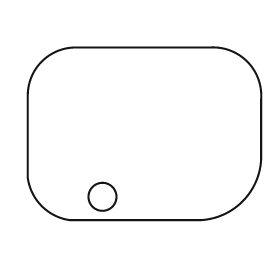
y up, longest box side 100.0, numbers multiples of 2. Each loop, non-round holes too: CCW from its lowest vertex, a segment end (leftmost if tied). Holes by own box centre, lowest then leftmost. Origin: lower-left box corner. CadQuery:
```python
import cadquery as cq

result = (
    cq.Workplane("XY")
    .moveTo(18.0, 0.0)
    .lineTo(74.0, 0.0)
    .threePointArc((92.0, 8.0), (100.0, 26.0))
    .lineTo(100.0, 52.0)
    .threePointArc((94.0, 68.0), (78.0, 74.0))
    .lineTo(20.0, 74.0)
    .threePointArc((6.0, 68.0), (0.0, 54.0))
    .lineTo(0.0, 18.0)
    .threePointArc((6.0, 6.0), (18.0, 0.0))
    .close()
    .moveTo(32.0, 10.0)
    .circle(6.0)
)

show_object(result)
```